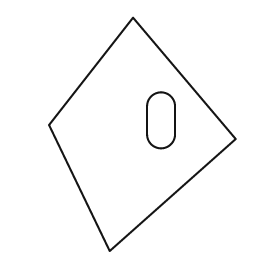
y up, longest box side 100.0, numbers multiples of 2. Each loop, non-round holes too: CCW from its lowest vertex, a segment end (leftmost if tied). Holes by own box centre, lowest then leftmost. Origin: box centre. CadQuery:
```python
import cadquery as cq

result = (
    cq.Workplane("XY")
    .moveTo(-14.0, -50.0)
    .lineTo(40.0, -2.0)
    .lineTo(-4.0, 50.0)
    .lineTo(-40.0, 4.0)
    .close()
    .moveTo(2.0, 0.0)
    .threePointArc((8.0, -6.0), (14.0, 0.0))
    .lineTo(14.0, 12.0)
    .threePointArc((8.0, 18.0), (2.0, 12.0))
    .close()
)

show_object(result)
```